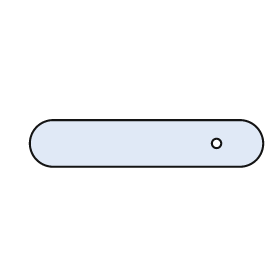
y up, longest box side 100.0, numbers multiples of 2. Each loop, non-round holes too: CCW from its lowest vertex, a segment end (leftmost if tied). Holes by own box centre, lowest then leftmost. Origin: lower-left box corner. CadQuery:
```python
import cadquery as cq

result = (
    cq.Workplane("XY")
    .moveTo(10.0, 0.0)
    .lineTo(90.0, 0.0)
    .threePointArc((100.0, 10.0), (90.0, 20.0))
    .lineTo(10.0, 20.0)
    .threePointArc((0.0, 10.0), (10.0, 0.0))
    .close()
    .moveTo(80.0, 10.0)
    .circle(2.0)
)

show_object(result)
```